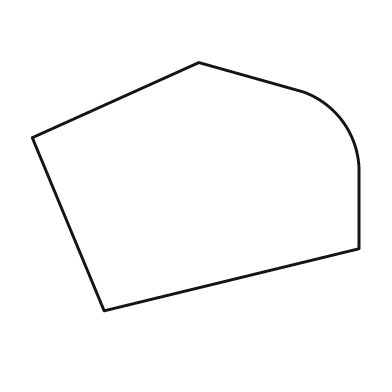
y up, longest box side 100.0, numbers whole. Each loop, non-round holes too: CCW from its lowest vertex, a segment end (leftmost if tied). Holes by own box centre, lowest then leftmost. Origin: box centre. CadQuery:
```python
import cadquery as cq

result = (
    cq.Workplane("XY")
    .moveTo(-28.0, -38.0)
    .lineTo(50.0, -19.0)
    .lineTo(50.0, 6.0)
    .threePointArc((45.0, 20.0), (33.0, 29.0))
    .lineTo(1.0, 38.0)
    .lineTo(-50.0, 15.0)
    .close()
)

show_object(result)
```